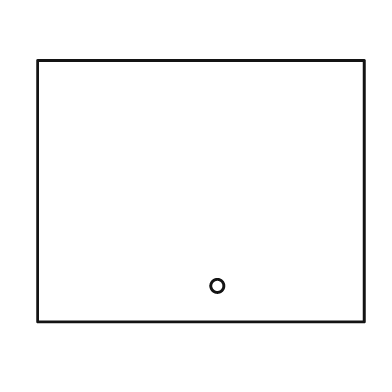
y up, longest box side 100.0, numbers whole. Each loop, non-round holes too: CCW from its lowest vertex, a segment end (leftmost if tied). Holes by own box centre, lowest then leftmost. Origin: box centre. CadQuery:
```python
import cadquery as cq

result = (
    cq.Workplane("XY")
    .moveTo(-50.0, -40.0)
    .lineTo(50.0, -40.0)
    .lineTo(50.0, 40.0)
    .lineTo(-50.0, 40.0)
    .close()
    .moveTo(5.0, -29.0)
    .circle(2.0)
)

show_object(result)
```